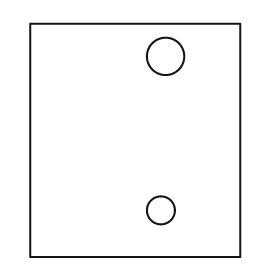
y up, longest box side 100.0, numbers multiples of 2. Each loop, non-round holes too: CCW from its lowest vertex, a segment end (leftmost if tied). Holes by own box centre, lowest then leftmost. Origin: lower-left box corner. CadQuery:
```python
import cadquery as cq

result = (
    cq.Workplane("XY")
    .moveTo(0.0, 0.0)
    .lineTo(90.0, 0.0)
    .lineTo(90.0, 100.0)
    .lineTo(0.0, 100.0)
    .close()
    .moveTo(56.0, 20.0)
    .circle(6.0)
    .moveTo(58.0, 86.0)
    .circle(8.0)
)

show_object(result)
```